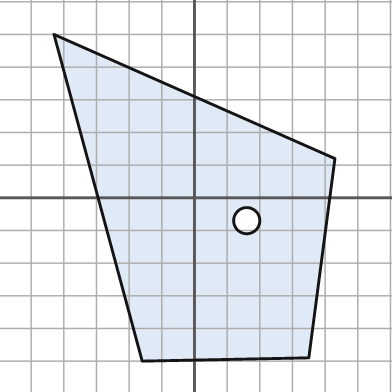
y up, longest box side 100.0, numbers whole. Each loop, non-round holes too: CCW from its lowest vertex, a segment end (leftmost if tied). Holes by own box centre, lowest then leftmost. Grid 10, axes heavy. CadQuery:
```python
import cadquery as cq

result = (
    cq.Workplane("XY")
    .moveTo(-16.0, -50.0)
    .lineTo(35.0, -49.0)
    .lineTo(43.0, 12.0)
    .lineTo(-43.0, 50.0)
    .close()
    .moveTo(16.0, -7.0)
    .circle(4.0)
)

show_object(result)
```